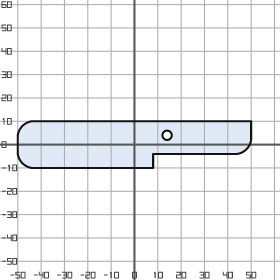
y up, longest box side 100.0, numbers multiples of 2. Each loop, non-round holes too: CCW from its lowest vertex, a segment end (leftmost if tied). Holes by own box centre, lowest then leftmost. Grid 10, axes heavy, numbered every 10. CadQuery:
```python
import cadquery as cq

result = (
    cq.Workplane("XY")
    .moveTo(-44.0, -10.0)
    .lineTo(8.0, -10.0)
    .lineTo(8.0, -4.0)
    .lineTo(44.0, -4.0)
    .threePointArc((48.0, -2.0), (50.0, 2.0))
    .lineTo(50.0, 10.0)
    .lineTo(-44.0, 10.0)
    .threePointArc((-48.0, 8.0), (-50.0, 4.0))
    .lineTo(-50.0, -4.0)
    .threePointArc((-48.0, -8.0), (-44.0, -10.0))
    .close()
    .moveTo(14.0, 4.0)
    .circle(2.0)
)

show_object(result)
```